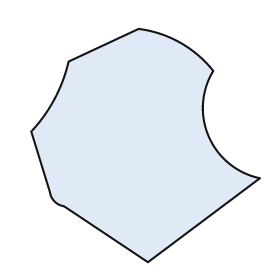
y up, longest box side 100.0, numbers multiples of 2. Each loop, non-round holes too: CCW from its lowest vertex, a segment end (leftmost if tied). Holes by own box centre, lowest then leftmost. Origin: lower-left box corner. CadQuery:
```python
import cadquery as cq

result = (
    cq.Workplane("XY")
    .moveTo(50.0, 0.0)
    .lineTo(98.0, 36.0)
    .threePointArc((76.0, 54.0), (78.0, 82.0))
    .threePointArc((64.0, 94.0), (46.0, 100.0))
    .lineTo(16.0, 86.0)
    .threePointArc((10.0, 70.0), (0.0, 56.0))
    .lineTo(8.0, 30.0)
    .threePointArc((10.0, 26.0), (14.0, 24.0))
    .close()
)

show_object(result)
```